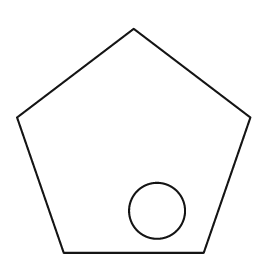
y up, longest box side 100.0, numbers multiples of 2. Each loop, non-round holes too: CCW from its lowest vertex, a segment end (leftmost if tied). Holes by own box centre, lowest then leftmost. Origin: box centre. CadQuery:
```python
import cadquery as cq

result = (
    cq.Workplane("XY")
    .moveTo(-30.0, -48.0)
    .lineTo(30.0, -48.0)
    .lineTo(50.0, 10.0)
    .lineTo(0.0, 48.0)
    .lineTo(-50.0, 10.0)
    .close()
    .moveTo(10.0, -30.0)
    .circle(12.0)
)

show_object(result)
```